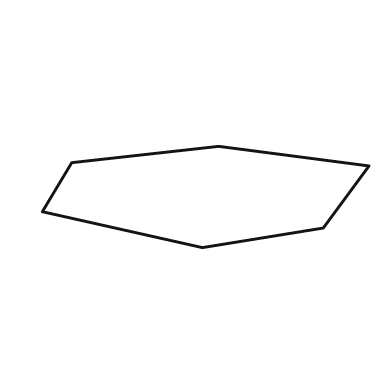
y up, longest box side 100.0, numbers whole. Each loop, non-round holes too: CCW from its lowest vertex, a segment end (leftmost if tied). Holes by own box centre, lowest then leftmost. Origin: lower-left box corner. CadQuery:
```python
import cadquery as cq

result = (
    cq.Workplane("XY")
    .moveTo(49.0, 0.0)
    .lineTo(86.0, 6.0)
    .lineTo(100.0, 25.0)
    .lineTo(54.0, 31.0)
    .lineTo(9.0, 26.0)
    .lineTo(0.0, 11.0)
    .close()
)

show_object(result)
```